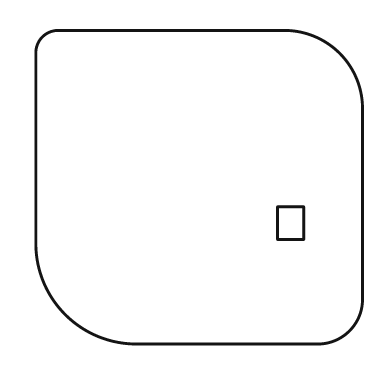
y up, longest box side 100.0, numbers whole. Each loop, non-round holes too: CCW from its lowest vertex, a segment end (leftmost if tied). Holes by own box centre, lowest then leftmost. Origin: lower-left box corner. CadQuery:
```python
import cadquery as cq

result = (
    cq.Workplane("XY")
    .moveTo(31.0, 0.0)
    .lineTo(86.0, 0.0)
    .threePointArc((96.0, 4.0), (100.0, 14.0))
    .lineTo(100.0, 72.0)
    .threePointArc((93.0, 89.0), (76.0, 96.0))
    .lineTo(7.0, 96.0)
    .threePointArc((2.0, 94.0), (0.0, 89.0))
    .lineTo(0.0, 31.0)
    .threePointArc((9.0, 9.0), (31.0, 0.0))
    .close()
    .moveTo(74.0, 32.0)
    .lineTo(82.0, 32.0)
    .lineTo(82.0, 42.0)
    .lineTo(74.0, 42.0)
    .close()
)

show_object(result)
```